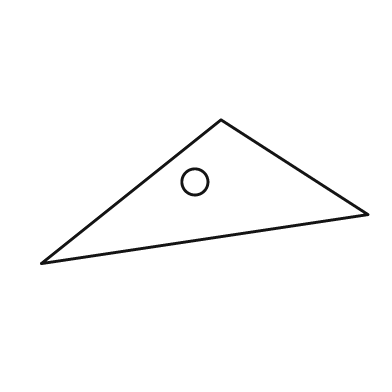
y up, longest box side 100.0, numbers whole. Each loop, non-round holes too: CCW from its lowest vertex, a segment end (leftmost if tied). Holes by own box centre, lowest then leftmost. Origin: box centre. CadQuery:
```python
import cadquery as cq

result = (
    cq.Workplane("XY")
    .moveTo(-50.0, -22.0)
    .lineTo(50.0, -7.0)
    .lineTo(5.0, 22.0)
    .close()
    .moveTo(-3.0, 3.0)
    .circle(4.0)
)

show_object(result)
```